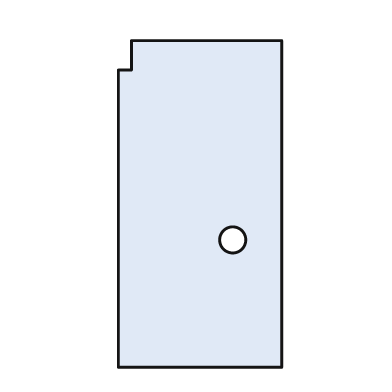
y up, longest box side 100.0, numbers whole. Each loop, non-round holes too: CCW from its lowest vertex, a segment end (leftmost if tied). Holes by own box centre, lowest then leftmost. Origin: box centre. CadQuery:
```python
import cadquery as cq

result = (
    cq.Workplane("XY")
    .moveTo(-25.0, -50.0)
    .lineTo(25.0, -50.0)
    .lineTo(25.0, 50.0)
    .lineTo(-21.0, 50.0)
    .lineTo(-21.0, 41.0)
    .lineTo(-25.0, 41.0)
    .close()
    .moveTo(10.0, -11.0)
    .circle(4.0)
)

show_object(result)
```